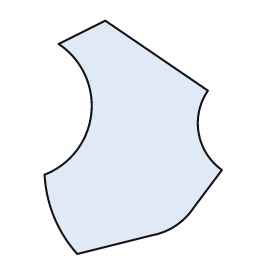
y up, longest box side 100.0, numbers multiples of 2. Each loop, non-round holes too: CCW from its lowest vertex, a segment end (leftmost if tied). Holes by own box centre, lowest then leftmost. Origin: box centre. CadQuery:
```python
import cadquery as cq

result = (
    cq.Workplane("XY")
    .moveTo(-24.0, -50.0)
    .lineTo(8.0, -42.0)
    .threePointArc((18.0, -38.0), (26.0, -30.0))
    .lineTo(38.0, -14.0)
    .threePointArc((28.0, 2.0), (32.0, 20.0))
    .lineTo(-12.0, 50.0)
    .lineTo(-32.0, 40.0)
    .threePointArc((-18.0, 10.0), (-38.0, -16.0))
    .threePointArc((-34.0, -34.0), (-24.0, -50.0))
    .close()
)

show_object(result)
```